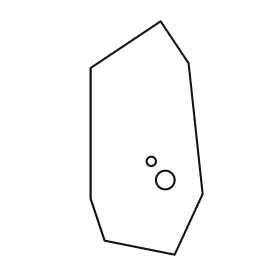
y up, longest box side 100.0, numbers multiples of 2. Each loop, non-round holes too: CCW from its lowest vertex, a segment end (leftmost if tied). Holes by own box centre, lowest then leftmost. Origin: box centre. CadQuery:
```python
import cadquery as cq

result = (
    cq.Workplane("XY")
    .moveTo(12.0, -50.0)
    .lineTo(24.0, -24.0)
    .lineTo(18.0, 32.0)
    .lineTo(6.0, 50.0)
    .lineTo(-24.0, 30.0)
    .lineTo(-24.0, -26.0)
    .lineTo(-18.0, -44.0)
    .close()
    .moveTo(8.0, -18.0)
    .circle(4.0)
    .moveTo(2.0, -10.0)
    .circle(2.0)
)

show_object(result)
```